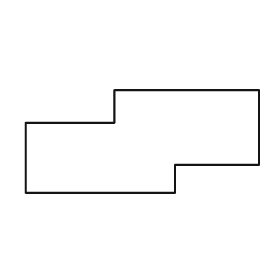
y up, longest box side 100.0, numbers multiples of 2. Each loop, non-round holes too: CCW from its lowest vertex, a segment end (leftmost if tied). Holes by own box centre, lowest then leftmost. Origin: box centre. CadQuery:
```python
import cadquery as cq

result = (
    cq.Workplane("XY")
    .moveTo(-50.0, -22.0)
    .lineTo(14.0, -22.0)
    .lineTo(14.0, -10.0)
    .lineTo(50.0, -10.0)
    .lineTo(50.0, 22.0)
    .lineTo(-12.0, 22.0)
    .lineTo(-12.0, 8.0)
    .lineTo(-50.0, 8.0)
    .close()
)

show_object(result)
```